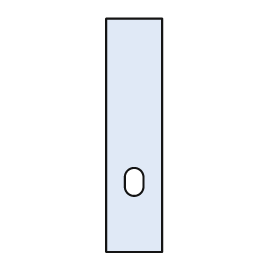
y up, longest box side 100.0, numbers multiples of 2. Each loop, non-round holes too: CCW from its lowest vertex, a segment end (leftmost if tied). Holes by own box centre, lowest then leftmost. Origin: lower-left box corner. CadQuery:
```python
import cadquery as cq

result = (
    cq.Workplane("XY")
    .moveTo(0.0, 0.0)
    .lineTo(24.0, 0.0)
    .lineTo(24.0, 100.0)
    .lineTo(0.0, 100.0)
    .close()
    .moveTo(8.0, 28.0)
    .threePointArc((12.0, 24.0), (16.0, 28.0))
    .lineTo(16.0, 32.0)
    .threePointArc((12.0, 36.0), (8.0, 32.0))
    .close()
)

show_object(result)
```